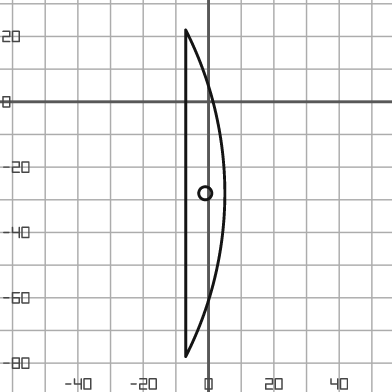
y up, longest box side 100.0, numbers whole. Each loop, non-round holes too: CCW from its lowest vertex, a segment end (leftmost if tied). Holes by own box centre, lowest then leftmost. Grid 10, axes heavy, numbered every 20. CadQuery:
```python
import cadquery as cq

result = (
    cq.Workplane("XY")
    .moveTo(-7.0, -78.0)
    .threePointArc((5.0, -28.0), (-7.0, 22.0))
    .close()
    .moveTo(-1.0, -28.0)
    .circle(2.0)
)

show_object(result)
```